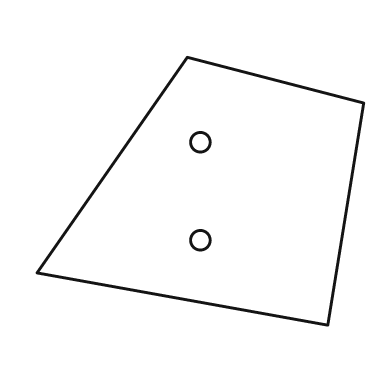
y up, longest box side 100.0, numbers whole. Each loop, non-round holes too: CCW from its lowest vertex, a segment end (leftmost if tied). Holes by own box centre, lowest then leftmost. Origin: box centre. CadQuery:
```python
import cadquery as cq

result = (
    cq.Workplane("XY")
    .moveTo(39.0, -41.0)
    .lineTo(50.0, 27.0)
    .lineTo(-4.0, 41.0)
    .lineTo(-50.0, -25.0)
    .close()
    .moveTo(0.0, -15.0)
    .circle(3.0)
    .moveTo(0.0, 15.0)
    .circle(3.0)
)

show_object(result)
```